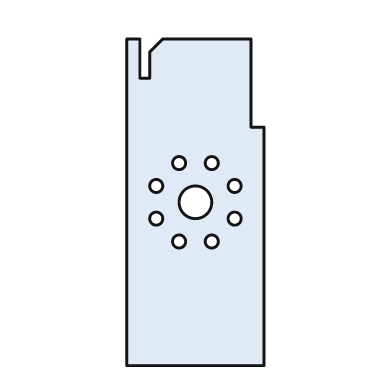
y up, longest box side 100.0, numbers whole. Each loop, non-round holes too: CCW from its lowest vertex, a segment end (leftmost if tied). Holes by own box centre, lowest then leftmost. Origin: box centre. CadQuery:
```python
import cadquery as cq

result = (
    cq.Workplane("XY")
    .moveTo(-21.0, -50.0)
    .lineTo(21.0, -50.0)
    .lineTo(21.0, 23.0)
    .lineTo(17.0, 23.0)
    .lineTo(17.0, 50.0)
    .lineTo(-10.0, 50.0)
    .lineTo(-14.0, 46.0)
    .lineTo(-14.0, 38.0)
    .lineTo(-17.0, 38.0)
    .lineTo(-17.0, 50.0)
    .lineTo(-21.0, 50.0)
    .close()
    .moveTo(-5.0, -12.0)
    .circle(2.0)
    .moveTo(5.0, -12.0)
    .circle(2.0)
    .moveTo(-12.0, -5.0)
    .circle(2.0)
    .moveTo(12.0, -5.0)
    .circle(2.0)
    .moveTo(0.0, 0.0)
    .circle(5.0)
    .moveTo(-12.0, 5.0)
    .circle(2.0)
    .moveTo(12.0, 5.0)
    .circle(2.0)
    .moveTo(-5.0, 12.0)
    .circle(2.0)
    .moveTo(5.0, 12.0)
    .circle(2.0)
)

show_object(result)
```